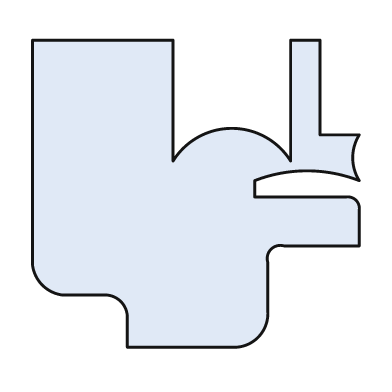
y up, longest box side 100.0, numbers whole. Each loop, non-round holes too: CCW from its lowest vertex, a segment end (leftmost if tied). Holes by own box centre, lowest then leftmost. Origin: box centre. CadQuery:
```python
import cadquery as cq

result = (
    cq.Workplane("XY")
    .moveTo(-21.0, -47.0)
    .lineTo(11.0, -47.0)
    .threePointArc((19.0, -44.0), (22.0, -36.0))
    .lineTo(22.0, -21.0)
    .threePointArc((23.0, -17.0), (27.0, -16.0))
    .lineTo(50.0, -16.0)
    .lineTo(50.0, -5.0)
    .threePointArc((49.0, -2.0), (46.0, -1.0))
    .lineTo(18.0, -1.0)
    .lineTo(18.0, 4.0)
    .threePointArc((34.0, 7.0), (50.0, 4.0))
    .threePointArc((48.0, 11.0), (50.0, 18.0))
    .lineTo(38.0, 18.0)
    .lineTo(38.0, 47.0)
    .lineTo(29.0, 47.0)
    .lineTo(29.0, 10.0)
    .threePointArc((11.0, 20.0), (-7.0, 10.0))
    .lineTo(-7.0, 47.0)
    .lineTo(-50.0, 47.0)
    .lineTo(-50.0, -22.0)
    .threePointArc((-47.0, -28.0), (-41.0, -31.0))
    .lineTo(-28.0, -31.0)
    .threePointArc((-23.0, -33.0), (-21.0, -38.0))
    .close()
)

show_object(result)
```